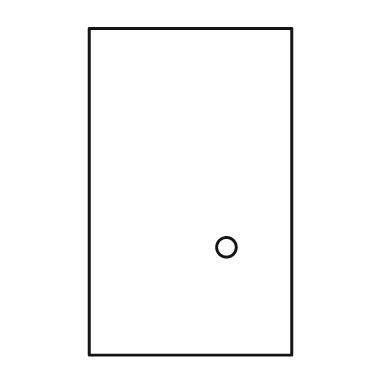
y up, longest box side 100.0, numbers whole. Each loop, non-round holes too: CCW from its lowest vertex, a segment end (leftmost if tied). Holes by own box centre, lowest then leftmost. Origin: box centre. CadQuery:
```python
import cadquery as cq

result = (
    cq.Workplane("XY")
    .moveTo(-31.0, -50.0)
    .lineTo(31.0, -50.0)
    .lineTo(31.0, 50.0)
    .lineTo(-31.0, 50.0)
    .close()
    .moveTo(11.0, -17.0)
    .circle(3.0)
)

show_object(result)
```